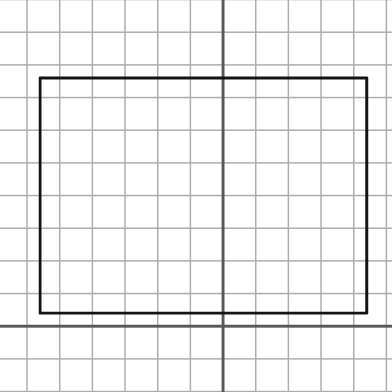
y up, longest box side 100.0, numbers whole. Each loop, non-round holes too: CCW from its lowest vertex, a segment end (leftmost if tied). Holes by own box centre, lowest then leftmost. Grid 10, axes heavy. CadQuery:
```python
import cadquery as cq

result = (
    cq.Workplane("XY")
    .moveTo(-56.0, 4.0)
    .lineTo(44.0, 4.0)
    .lineTo(44.0, 76.0)
    .lineTo(-56.0, 76.0)
    .close()
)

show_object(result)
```